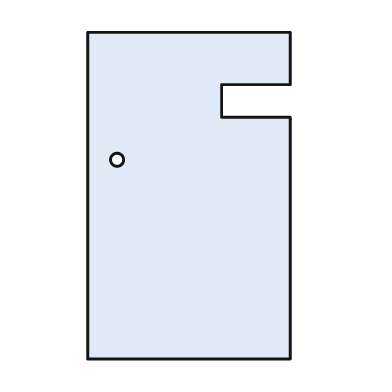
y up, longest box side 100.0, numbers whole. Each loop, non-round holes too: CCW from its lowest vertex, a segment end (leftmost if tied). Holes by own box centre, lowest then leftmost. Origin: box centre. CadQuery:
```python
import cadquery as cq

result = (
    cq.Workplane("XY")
    .moveTo(-31.0, -50.0)
    .lineTo(31.0, -50.0)
    .lineTo(31.0, 24.0)
    .lineTo(10.0, 24.0)
    .lineTo(10.0, 34.0)
    .lineTo(31.0, 34.0)
    .lineTo(31.0, 50.0)
    .lineTo(-31.0, 50.0)
    .close()
    .moveTo(-22.0, 11.0)
    .circle(2.0)
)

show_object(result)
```